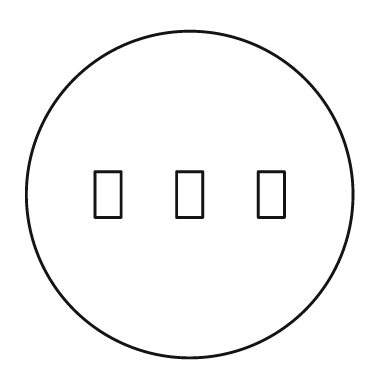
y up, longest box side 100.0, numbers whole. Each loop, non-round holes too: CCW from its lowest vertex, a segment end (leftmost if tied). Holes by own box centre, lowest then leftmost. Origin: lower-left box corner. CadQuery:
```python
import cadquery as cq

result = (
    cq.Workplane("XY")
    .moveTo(50.0, 50.0)
    .circle(50.0)
    .moveTo(21.0, 43.0)
    .lineTo(29.0, 43.0)
    .lineTo(29.0, 57.0)
    .lineTo(21.0, 57.0)
    .close()
    .moveTo(46.0, 43.0)
    .lineTo(54.0, 43.0)
    .lineTo(54.0, 57.0)
    .lineTo(46.0, 57.0)
    .close()
    .moveTo(71.0, 43.0)
    .lineTo(79.0, 43.0)
    .lineTo(79.0, 57.0)
    .lineTo(71.0, 57.0)
    .close()
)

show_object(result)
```